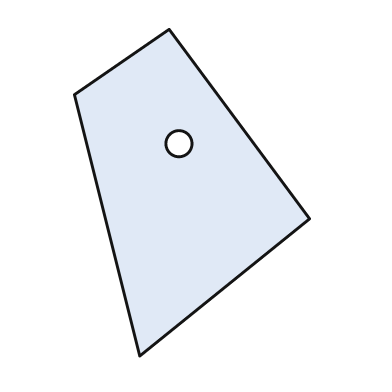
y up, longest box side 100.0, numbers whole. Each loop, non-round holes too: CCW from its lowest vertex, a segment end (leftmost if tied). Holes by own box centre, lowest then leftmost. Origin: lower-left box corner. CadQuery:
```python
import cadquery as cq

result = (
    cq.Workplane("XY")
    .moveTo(20.0, 0.0)
    .lineTo(72.0, 42.0)
    .lineTo(29.0, 100.0)
    .lineTo(0.0, 80.0)
    .close()
    .moveTo(32.0, 65.0)
    .circle(4.0)
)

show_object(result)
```